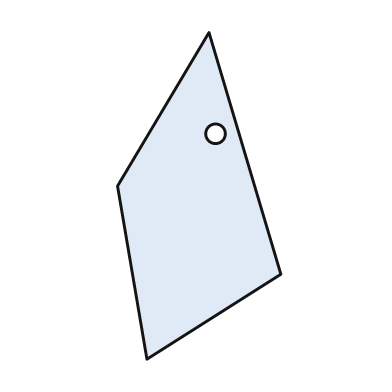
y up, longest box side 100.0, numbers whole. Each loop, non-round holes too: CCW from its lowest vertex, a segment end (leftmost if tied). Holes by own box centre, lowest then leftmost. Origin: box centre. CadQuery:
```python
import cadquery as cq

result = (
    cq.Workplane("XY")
    .moveTo(-16.0, -50.0)
    .lineTo(25.0, -24.0)
    .lineTo(3.0, 50.0)
    .lineTo(-25.0, 3.0)
    .close()
    .moveTo(5.0, 19.0)
    .circle(3.0)
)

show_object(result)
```